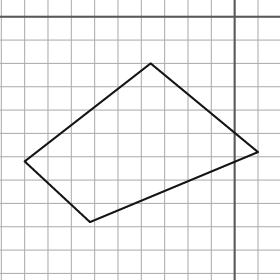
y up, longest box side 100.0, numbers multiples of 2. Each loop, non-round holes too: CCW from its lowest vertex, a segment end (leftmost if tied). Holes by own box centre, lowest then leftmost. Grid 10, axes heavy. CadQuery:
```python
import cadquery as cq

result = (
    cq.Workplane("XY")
    .moveTo(-62.0, -88.0)
    .lineTo(10.0, -58.0)
    .lineTo(-36.0, -20.0)
    .lineTo(-90.0, -62.0)
    .close()
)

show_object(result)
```